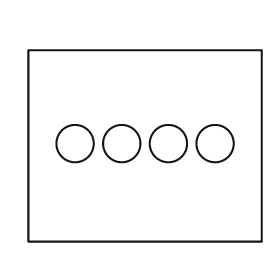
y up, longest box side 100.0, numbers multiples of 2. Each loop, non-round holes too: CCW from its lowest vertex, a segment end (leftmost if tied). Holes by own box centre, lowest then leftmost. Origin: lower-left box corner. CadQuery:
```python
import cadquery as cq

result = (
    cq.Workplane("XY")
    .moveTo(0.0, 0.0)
    .lineTo(100.0, 0.0)
    .lineTo(100.0, 82.0)
    .lineTo(0.0, 82.0)
    .close()
    .moveTo(20.0, 42.0)
    .circle(8.0)
    .moveTo(40.0, 42.0)
    .circle(8.0)
    .moveTo(60.0, 42.0)
    .circle(8.0)
    .moveTo(80.0, 42.0)
    .circle(8.0)
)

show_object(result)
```